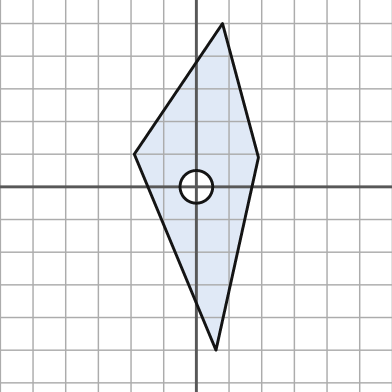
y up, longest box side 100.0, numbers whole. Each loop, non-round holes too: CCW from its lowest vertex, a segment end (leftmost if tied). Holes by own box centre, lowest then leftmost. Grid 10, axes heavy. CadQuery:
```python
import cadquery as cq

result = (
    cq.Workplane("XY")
    .moveTo(6.0, -50.0)
    .lineTo(19.0, 9.0)
    .lineTo(8.0, 50.0)
    .lineTo(-19.0, 10.0)
    .close()
    .moveTo(0.0, 0.0)
    .circle(5.0)
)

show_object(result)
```